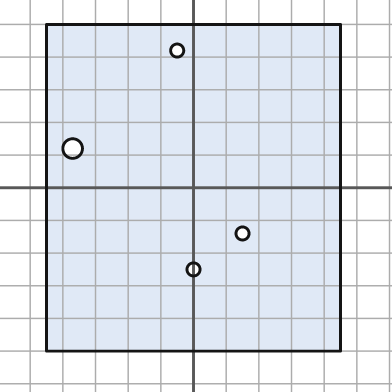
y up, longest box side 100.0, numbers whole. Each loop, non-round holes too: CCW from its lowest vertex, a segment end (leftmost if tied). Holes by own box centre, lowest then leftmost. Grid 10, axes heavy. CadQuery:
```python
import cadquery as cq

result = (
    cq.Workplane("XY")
    .moveTo(-45.0, -50.0)
    .lineTo(45.0, -50.0)
    .lineTo(45.0, 50.0)
    .lineTo(-45.0, 50.0)
    .close()
    .moveTo(0.0, -25.0)
    .circle(2.0)
    .moveTo(15.0, -14.0)
    .circle(2.0)
    .moveTo(-37.0, 12.0)
    .circle(3.0)
    .moveTo(-5.0, 42.0)
    .circle(2.0)
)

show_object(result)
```